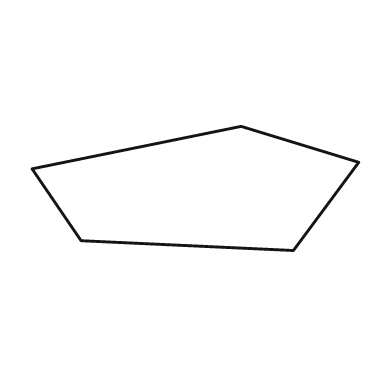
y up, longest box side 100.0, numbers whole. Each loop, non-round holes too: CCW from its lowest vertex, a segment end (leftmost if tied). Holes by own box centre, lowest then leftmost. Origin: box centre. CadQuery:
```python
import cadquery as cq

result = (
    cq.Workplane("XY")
    .moveTo(30.0, -19.0)
    .lineTo(50.0, 8.0)
    .lineTo(14.0, 19.0)
    .lineTo(-50.0, 6.0)
    .lineTo(-35.0, -16.0)
    .close()
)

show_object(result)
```